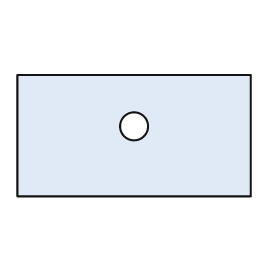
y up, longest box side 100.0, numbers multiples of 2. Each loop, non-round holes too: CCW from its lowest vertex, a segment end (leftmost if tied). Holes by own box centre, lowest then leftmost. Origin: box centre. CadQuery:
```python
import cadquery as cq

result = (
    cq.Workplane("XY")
    .moveTo(-50.0, -26.0)
    .lineTo(50.0, -26.0)
    .lineTo(50.0, 26.0)
    .lineTo(-50.0, 26.0)
    .close()
    .moveTo(0.0, 4.0)
    .circle(6.0)
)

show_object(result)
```